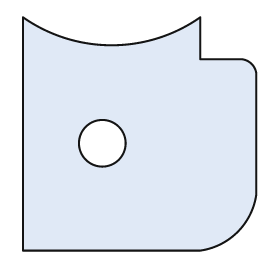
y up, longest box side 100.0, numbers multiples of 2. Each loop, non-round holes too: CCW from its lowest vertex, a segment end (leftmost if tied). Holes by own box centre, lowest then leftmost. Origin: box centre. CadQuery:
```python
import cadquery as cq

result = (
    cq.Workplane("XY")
    .moveTo(-50.0, -50.0)
    .lineTo(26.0, -50.0)
    .threePointArc((42.0, -42.0), (50.0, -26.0))
    .lineTo(50.0, 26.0)
    .threePointArc((48.0, 30.0), (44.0, 32.0))
    .lineTo(26.0, 32.0)
    .lineTo(26.0, 50.0)
    .threePointArc((-12.0, 38.0), (-50.0, 50.0))
    .close()
    .moveTo(-16.0, -4.0)
    .circle(10.0)
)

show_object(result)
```